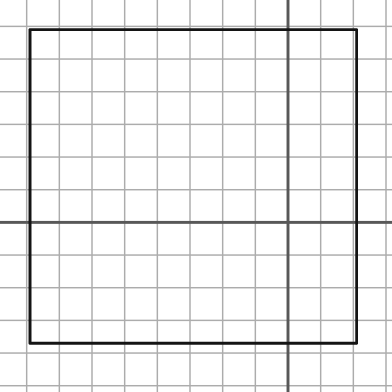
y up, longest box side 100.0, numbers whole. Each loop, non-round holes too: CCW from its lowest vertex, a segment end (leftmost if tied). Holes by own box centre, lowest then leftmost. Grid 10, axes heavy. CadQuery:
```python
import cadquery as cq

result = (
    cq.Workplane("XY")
    .moveTo(-79.0, -37.0)
    .lineTo(21.0, -37.0)
    .lineTo(21.0, 59.0)
    .lineTo(-79.0, 59.0)
    .close()
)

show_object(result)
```